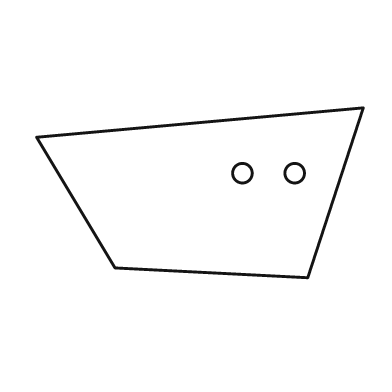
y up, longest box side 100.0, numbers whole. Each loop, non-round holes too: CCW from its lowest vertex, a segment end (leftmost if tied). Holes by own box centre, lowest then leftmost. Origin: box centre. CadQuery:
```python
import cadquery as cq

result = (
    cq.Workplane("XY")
    .moveTo(33.0, -26.0)
    .lineTo(50.0, 26.0)
    .lineTo(-50.0, 17.0)
    .lineTo(-26.0, -23.0)
    .close()
    .moveTo(13.0, 6.0)
    .circle(3.0)
    .moveTo(29.0, 6.0)
    .circle(3.0)
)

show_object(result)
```